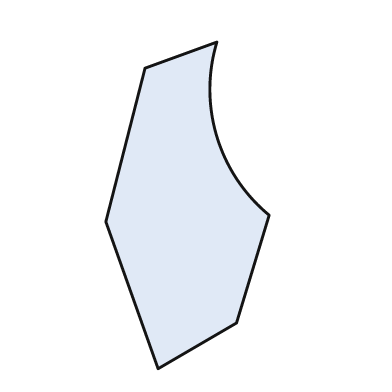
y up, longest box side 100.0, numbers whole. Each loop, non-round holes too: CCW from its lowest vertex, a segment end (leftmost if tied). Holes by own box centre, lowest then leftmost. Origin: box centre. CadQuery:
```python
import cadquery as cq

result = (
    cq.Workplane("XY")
    .moveTo(-9.0, -50.0)
    .lineTo(15.0, -36.0)
    .lineTo(25.0, -3.0)
    .threePointArc((9.0, 21.0), (9.0, 50.0))
    .lineTo(-13.0, 42.0)
    .lineTo(-25.0, -5.0)
    .close()
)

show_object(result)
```